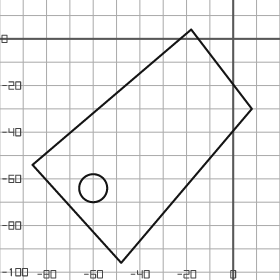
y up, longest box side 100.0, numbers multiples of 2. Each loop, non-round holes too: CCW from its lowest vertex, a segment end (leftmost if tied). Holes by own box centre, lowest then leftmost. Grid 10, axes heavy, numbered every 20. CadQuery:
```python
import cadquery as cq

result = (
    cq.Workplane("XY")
    .moveTo(-48.0, -96.0)
    .lineTo(8.0, -30.0)
    .lineTo(-18.0, 4.0)
    .lineTo(-86.0, -54.0)
    .close()
    .moveTo(-60.0, -64.0)
    .circle(6.0)
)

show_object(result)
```